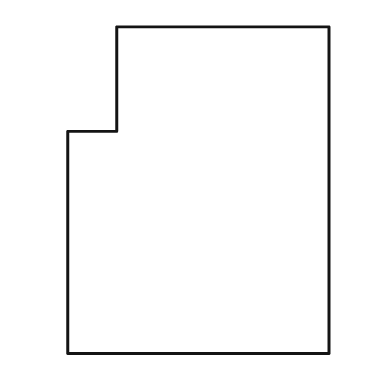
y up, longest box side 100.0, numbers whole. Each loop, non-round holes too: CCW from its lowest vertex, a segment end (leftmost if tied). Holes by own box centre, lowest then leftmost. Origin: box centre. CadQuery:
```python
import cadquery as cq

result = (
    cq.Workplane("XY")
    .moveTo(-40.0, -50.0)
    .lineTo(40.0, -50.0)
    .lineTo(40.0, 50.0)
    .lineTo(-25.0, 50.0)
    .lineTo(-25.0, 18.0)
    .lineTo(-40.0, 18.0)
    .close()
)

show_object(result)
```